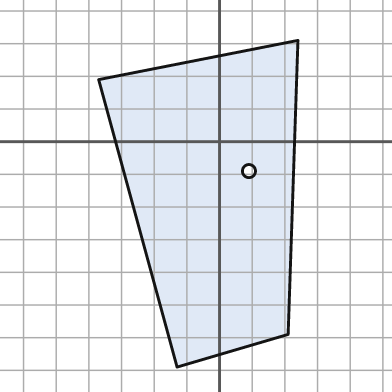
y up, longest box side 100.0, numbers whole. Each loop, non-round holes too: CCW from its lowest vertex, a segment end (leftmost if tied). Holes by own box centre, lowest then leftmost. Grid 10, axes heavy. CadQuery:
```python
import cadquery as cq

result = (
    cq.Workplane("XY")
    .moveTo(-13.0, -69.0)
    .lineTo(21.0, -59.0)
    .lineTo(24.0, 31.0)
    .lineTo(-37.0, 19.0)
    .close()
    .moveTo(9.0, -9.0)
    .circle(2.0)
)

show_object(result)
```